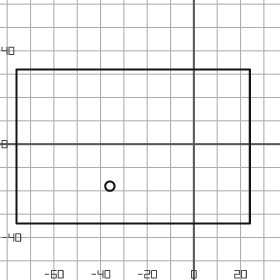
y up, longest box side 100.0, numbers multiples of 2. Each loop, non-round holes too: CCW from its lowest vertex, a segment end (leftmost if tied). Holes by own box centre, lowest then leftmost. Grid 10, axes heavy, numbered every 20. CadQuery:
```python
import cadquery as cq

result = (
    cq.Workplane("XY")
    .moveTo(-76.0, -34.0)
    .lineTo(24.0, -34.0)
    .lineTo(24.0, 32.0)
    .lineTo(-76.0, 32.0)
    .close()
    .moveTo(-36.0, -18.0)
    .circle(2.0)
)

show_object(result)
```